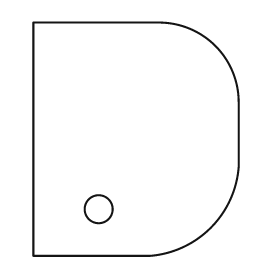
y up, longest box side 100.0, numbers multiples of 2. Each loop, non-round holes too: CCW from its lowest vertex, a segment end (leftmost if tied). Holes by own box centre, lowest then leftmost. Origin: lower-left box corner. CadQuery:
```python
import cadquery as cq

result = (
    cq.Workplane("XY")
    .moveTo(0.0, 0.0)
    .lineTo(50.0, 0.0)
    .threePointArc((76.0, 12.0), (88.0, 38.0))
    .lineTo(88.0, 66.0)
    .threePointArc((78.0, 90.0), (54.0, 100.0))
    .lineTo(0.0, 100.0)
    .close()
    .moveTo(28.0, 20.0)
    .circle(6.0)
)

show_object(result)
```